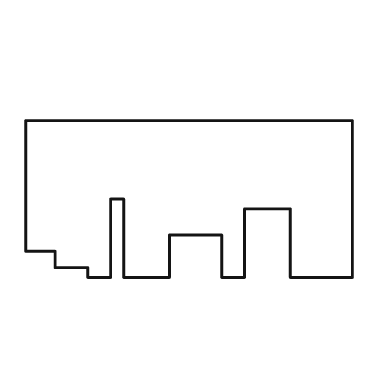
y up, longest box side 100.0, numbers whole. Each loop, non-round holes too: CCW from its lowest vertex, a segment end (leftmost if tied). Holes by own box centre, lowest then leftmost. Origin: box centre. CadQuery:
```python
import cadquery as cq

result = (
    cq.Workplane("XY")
    .moveTo(-31.0, -24.0)
    .lineTo(-24.0, -24.0)
    .lineTo(-24.0, 0.0)
    .lineTo(-20.0, 0.0)
    .lineTo(-20.0, -24.0)
    .lineTo(-6.0, -24.0)
    .lineTo(-6.0, -11.0)
    .lineTo(10.0, -11.0)
    .lineTo(10.0, -24.0)
    .lineTo(17.0, -24.0)
    .lineTo(17.0, -3.0)
    .lineTo(31.0, -3.0)
    .lineTo(31.0, -24.0)
    .lineTo(50.0, -24.0)
    .lineTo(50.0, 24.0)
    .lineTo(-50.0, 24.0)
    .lineTo(-50.0, -16.0)
    .lineTo(-41.0, -16.0)
    .lineTo(-41.0, -21.0)
    .lineTo(-31.0, -21.0)
    .close()
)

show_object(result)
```